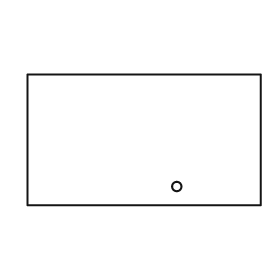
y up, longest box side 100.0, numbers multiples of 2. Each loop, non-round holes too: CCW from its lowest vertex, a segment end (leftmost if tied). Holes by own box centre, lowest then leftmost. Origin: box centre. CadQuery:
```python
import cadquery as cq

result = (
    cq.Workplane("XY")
    .moveTo(-50.0, -28.0)
    .lineTo(50.0, -28.0)
    .lineTo(50.0, 28.0)
    .lineTo(-50.0, 28.0)
    .close()
    .moveTo(14.0, -20.0)
    .circle(2.0)
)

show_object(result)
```